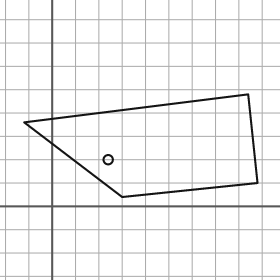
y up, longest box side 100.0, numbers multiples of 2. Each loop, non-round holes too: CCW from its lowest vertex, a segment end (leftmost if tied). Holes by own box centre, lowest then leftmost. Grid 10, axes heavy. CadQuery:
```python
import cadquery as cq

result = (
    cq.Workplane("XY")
    .moveTo(30.0, 4.0)
    .lineTo(88.0, 10.0)
    .lineTo(84.0, 48.0)
    .lineTo(-12.0, 36.0)
    .close()
    .moveTo(24.0, 20.0)
    .circle(2.0)
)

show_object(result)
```